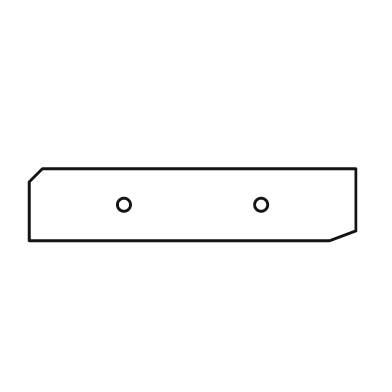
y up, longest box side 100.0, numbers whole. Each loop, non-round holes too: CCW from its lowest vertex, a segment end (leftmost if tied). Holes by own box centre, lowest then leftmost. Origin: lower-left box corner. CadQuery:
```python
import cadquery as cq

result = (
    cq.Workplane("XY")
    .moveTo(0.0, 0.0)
    .lineTo(92.0, 0.0)
    .lineTo(100.0, 3.0)
    .lineTo(100.0, 22.0)
    .lineTo(4.0, 22.0)
    .lineTo(0.0, 18.0)
    .close()
    .moveTo(29.0, 11.0)
    .circle(2.0)
    .moveTo(71.0, 11.0)
    .circle(2.0)
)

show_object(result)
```